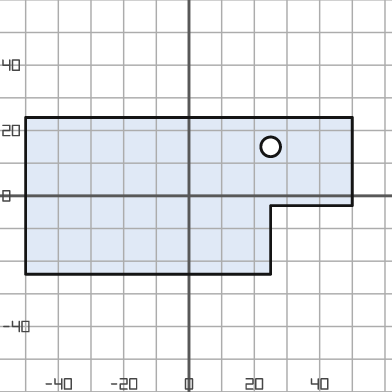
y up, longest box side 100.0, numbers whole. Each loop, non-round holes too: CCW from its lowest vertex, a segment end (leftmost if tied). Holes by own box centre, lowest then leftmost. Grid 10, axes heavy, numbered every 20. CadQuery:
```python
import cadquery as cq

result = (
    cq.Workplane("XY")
    .moveTo(-50.0, -24.0)
    .lineTo(25.0, -24.0)
    .lineTo(25.0, -3.0)
    .lineTo(50.0, -3.0)
    .lineTo(50.0, 24.0)
    .lineTo(-50.0, 24.0)
    .close()
    .moveTo(25.0, 15.0)
    .circle(3.0)
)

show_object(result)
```